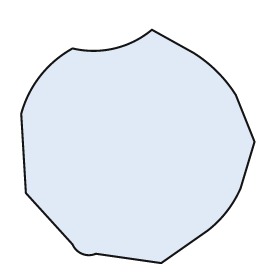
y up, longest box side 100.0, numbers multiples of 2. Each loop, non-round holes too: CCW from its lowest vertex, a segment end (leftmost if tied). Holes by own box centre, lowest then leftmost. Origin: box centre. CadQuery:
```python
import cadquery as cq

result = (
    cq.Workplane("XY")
    .moveTo(10.0, -50.0)
    .lineTo(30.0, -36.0)
    .threePointArc((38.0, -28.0), (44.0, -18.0))
    .lineTo(50.0, 2.0)
    .lineTo(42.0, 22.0)
    .threePointArc((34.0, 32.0), (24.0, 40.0))
    .lineTo(6.0, 50.0)
    .threePointArc((-10.0, 42.0), (-28.0, 42.0))
    .threePointArc((-42.0, 30.0), (-50.0, 14.0))
    .lineTo(-48.0, -20.0)
    .lineTo(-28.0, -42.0)
    .threePointArc((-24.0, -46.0), (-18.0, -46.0))
    .close()
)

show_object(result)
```